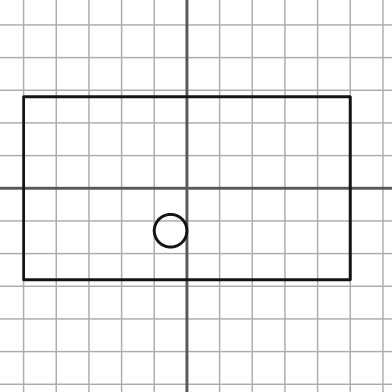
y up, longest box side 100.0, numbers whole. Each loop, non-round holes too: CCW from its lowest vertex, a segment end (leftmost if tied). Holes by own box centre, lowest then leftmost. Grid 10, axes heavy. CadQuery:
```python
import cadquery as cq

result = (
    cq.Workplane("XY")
    .moveTo(-50.0, -28.0)
    .lineTo(50.0, -28.0)
    .lineTo(50.0, 28.0)
    .lineTo(-50.0, 28.0)
    .close()
    .moveTo(-5.0, -13.0)
    .circle(5.0)
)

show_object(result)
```